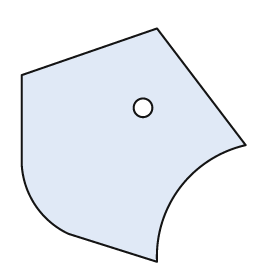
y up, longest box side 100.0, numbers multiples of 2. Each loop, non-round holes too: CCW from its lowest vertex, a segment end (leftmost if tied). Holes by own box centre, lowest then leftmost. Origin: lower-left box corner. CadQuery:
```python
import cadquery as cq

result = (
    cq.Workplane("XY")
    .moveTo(58.0, 0.0)
    .threePointArc((68.0, 32.0), (96.0, 50.0))
    .lineTo(58.0, 100.0)
    .lineTo(0.0, 80.0)
    .lineTo(0.0, 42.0)
    .threePointArc((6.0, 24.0), (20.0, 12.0))
    .close()
    .moveTo(52.0, 66.0)
    .circle(4.0)
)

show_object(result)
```